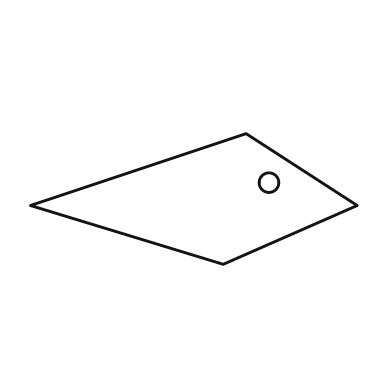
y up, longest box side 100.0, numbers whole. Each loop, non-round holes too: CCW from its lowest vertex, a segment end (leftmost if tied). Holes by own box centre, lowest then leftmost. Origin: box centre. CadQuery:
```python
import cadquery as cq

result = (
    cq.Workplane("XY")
    .moveTo(9.0, -20.0)
    .lineTo(50.0, -2.0)
    .lineTo(16.0, 20.0)
    .lineTo(-50.0, -2.0)
    .close()
    .moveTo(23.0, 5.0)
    .circle(3.0)
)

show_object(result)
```